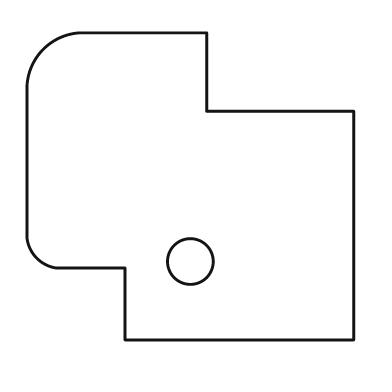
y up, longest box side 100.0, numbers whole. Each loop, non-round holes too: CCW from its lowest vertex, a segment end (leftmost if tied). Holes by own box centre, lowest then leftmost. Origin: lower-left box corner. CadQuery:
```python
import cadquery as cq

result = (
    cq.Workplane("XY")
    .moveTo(30.0, 0.0)
    .lineTo(100.0, 0.0)
    .lineTo(100.0, 70.0)
    .lineTo(55.0, 70.0)
    .lineTo(55.0, 94.0)
    .lineTo(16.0, 94.0)
    .threePointArc((5.0, 89.0), (0.0, 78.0))
    .lineTo(0.0, 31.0)
    .threePointArc((3.0, 25.0), (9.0, 22.0))
    .lineTo(30.0, 22.0)
    .close()
    .moveTo(50.0, 24.0)
    .circle(7.0)
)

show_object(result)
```